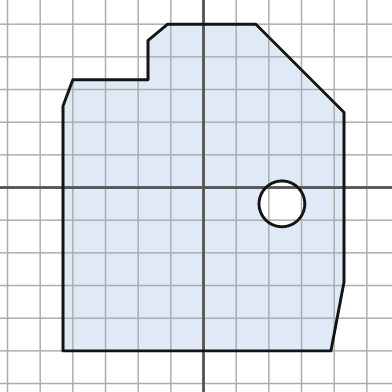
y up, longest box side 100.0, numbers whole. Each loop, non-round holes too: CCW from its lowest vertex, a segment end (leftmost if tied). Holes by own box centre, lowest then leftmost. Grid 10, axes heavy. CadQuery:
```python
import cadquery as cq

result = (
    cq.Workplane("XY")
    .moveTo(-43.0, -50.0)
    .lineTo(39.0, -50.0)
    .lineTo(43.0, -29.0)
    .lineTo(43.0, 23.0)
    .lineTo(16.0, 50.0)
    .lineTo(-11.0, 50.0)
    .lineTo(-17.0, 45.0)
    .lineTo(-17.0, 33.0)
    .lineTo(-40.0, 33.0)
    .lineTo(-43.0, 25.0)
    .close()
    .moveTo(24.0, -5.0)
    .circle(7.0)
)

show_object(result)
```